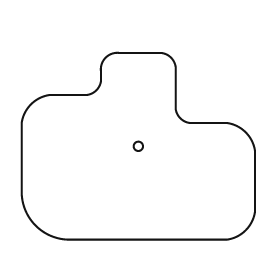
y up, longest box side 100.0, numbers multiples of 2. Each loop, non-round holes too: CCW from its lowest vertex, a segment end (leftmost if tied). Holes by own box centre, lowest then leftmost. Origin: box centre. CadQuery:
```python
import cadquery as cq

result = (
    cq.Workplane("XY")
    .moveTo(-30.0, -40.0)
    .lineTo(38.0, -40.0)
    .threePointArc((46.0, -36.0), (50.0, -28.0))
    .lineTo(50.0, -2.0)
    .threePointArc((46.0, 6.0), (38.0, 10.0))
    .lineTo(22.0, 10.0)
    .threePointArc((18.0, 12.0), (16.0, 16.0))
    .lineTo(16.0, 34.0)
    .threePointArc((14.0, 38.0), (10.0, 40.0))
    .lineTo(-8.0, 40.0)
    .threePointArc((-14.0, 38.0), (-16.0, 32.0))
    .lineTo(-16.0, 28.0)
    .threePointArc((-18.0, 24.0), (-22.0, 22.0))
    .lineTo(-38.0, 22.0)
    .threePointArc((-46.0, 18.0), (-50.0, 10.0))
    .lineTo(-50.0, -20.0)
    .threePointArc((-44.0, -34.0), (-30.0, -40.0))
    .close()
    .moveTo(0.0, 0.0)
    .circle(2.0)
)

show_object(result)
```